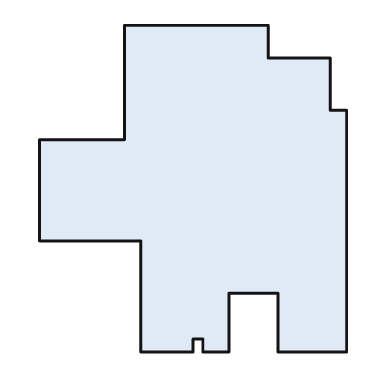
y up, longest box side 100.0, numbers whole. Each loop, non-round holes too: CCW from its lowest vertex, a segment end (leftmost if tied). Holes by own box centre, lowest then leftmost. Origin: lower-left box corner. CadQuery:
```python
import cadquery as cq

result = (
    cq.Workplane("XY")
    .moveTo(31.0, 0.0)
    .lineTo(47.0, 0.0)
    .lineTo(47.0, 4.0)
    .lineTo(50.0, 4.0)
    .lineTo(50.0, 0.0)
    .lineTo(58.0, 0.0)
    .lineTo(58.0, 18.0)
    .lineTo(73.0, 18.0)
    .lineTo(73.0, 0.0)
    .lineTo(94.0, 0.0)
    .lineTo(94.0, 74.0)
    .lineTo(89.0, 74.0)
    .lineTo(89.0, 90.0)
    .lineTo(70.0, 90.0)
    .lineTo(70.0, 100.0)
    .lineTo(26.0, 100.0)
    .lineTo(26.0, 65.0)
    .lineTo(0.0, 65.0)
    .lineTo(0.0, 34.0)
    .lineTo(31.0, 34.0)
    .close()
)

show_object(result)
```